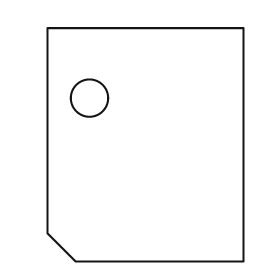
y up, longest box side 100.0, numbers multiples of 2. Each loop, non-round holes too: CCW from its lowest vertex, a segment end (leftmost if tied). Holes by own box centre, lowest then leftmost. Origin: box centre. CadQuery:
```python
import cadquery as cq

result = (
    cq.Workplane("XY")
    .moveTo(-30.0, -50.0)
    .lineTo(42.0, -50.0)
    .lineTo(42.0, 50.0)
    .lineTo(-42.0, 50.0)
    .lineTo(-42.0, -38.0)
    .close()
    .moveTo(-24.0, 20.0)
    .circle(8.0)
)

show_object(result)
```